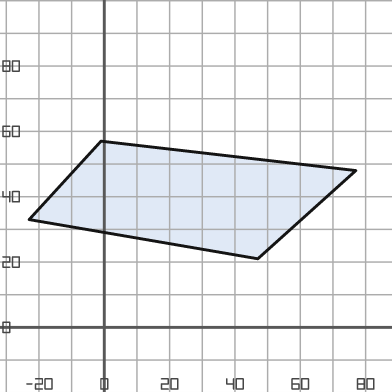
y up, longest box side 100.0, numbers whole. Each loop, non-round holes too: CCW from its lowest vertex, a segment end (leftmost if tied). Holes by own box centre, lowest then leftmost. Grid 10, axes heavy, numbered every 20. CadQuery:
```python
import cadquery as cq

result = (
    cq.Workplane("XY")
    .moveTo(47.0, 21.0)
    .lineTo(77.0, 48.0)
    .lineTo(-1.0, 57.0)
    .lineTo(-23.0, 33.0)
    .close()
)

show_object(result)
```